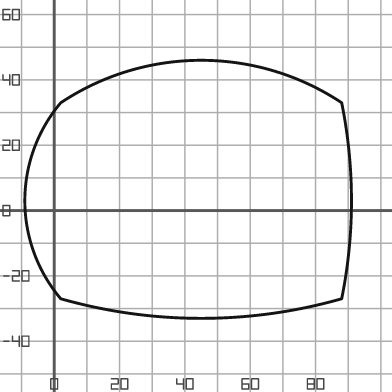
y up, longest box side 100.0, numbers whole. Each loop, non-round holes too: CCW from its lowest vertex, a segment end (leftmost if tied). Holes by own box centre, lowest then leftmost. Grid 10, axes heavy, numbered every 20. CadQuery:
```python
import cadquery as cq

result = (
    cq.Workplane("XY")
    .moveTo(2.0, -27.0)
    .threePointArc((45.0, -33.0), (88.0, -27.0))
    .threePointArc((91.0, 3.0), (88.0, 33.0))
    .threePointArc((45.0, 46.0), (2.0, 33.0))
    .threePointArc((-9.0, 3.0), (2.0, -27.0))
    .close()
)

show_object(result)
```